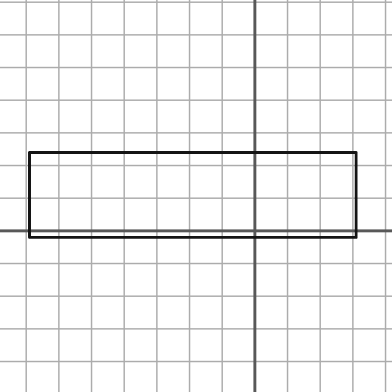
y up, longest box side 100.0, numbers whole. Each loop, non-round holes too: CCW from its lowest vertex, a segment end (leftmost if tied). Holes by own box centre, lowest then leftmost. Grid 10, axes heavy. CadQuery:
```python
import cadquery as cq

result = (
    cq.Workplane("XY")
    .moveTo(-69.0, -2.0)
    .lineTo(31.0, -2.0)
    .lineTo(31.0, 24.0)
    .lineTo(-69.0, 24.0)
    .close()
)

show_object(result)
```